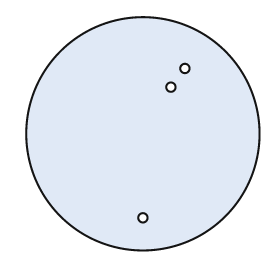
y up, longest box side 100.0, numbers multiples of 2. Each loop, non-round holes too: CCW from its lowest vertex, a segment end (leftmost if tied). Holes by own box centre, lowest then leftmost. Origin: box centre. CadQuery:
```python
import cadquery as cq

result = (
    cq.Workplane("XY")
    .moveTo(0.0, 0.0)
    .circle(50.0)
    .moveTo(0.0, -36.0)
    .circle(2.0)
    .moveTo(12.0, 20.0)
    .circle(2.0)
    .moveTo(18.0, 28.0)
    .circle(2.0)
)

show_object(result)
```